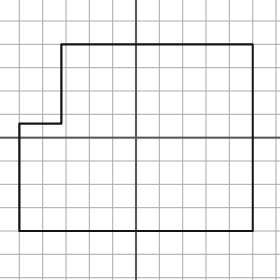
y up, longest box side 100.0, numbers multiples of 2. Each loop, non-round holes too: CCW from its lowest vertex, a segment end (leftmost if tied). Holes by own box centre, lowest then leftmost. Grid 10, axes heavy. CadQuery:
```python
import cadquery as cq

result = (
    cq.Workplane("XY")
    .moveTo(-50.0, -40.0)
    .lineTo(50.0, -40.0)
    .lineTo(50.0, 40.0)
    .lineTo(-32.0, 40.0)
    .lineTo(-32.0, 6.0)
    .lineTo(-50.0, 6.0)
    .close()
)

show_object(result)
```